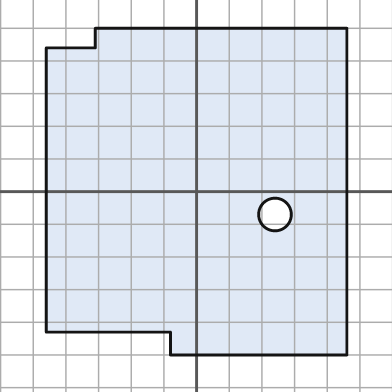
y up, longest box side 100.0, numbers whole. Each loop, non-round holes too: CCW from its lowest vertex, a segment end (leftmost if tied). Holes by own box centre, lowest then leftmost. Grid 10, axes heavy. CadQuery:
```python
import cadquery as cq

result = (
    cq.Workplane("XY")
    .moveTo(-8.0, -50.0)
    .lineTo(46.0, -50.0)
    .lineTo(46.0, 50.0)
    .lineTo(-31.0, 50.0)
    .lineTo(-31.0, 44.0)
    .lineTo(-46.0, 44.0)
    .lineTo(-46.0, -43.0)
    .lineTo(-8.0, -43.0)
    .close()
    .moveTo(24.0, -7.0)
    .circle(5.0)
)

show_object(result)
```